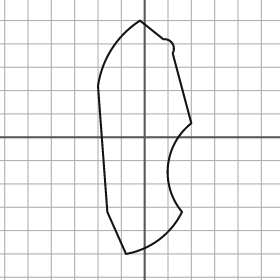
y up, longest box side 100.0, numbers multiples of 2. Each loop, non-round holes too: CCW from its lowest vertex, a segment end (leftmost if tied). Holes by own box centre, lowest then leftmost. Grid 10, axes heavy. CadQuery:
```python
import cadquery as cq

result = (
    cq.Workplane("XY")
    .moveTo(-8.0, -50.0)
    .threePointArc((6.0, -44.0), (16.0, -32.0))
    .threePointArc((10.0, -12.0), (20.0, 6.0))
    .lineTo(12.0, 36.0)
    .threePointArc((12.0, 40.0), (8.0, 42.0))
    .lineTo(-2.0, 50.0)
    .threePointArc((-14.0, 38.0), (-20.0, 22.0))
    .lineTo(-16.0, -32.0)
    .close()
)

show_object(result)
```